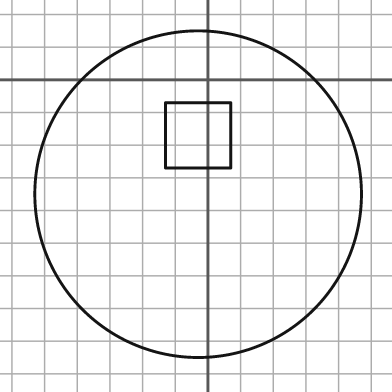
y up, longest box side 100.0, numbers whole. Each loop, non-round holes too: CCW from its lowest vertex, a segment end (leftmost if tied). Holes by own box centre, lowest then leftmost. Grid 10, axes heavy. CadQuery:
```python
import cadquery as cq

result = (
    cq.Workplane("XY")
    .moveTo(-3.0, -35.0)
    .circle(50.0)
    .moveTo(-13.0, -27.0)
    .lineTo(7.0, -27.0)
    .lineTo(7.0, -7.0)
    .lineTo(-13.0, -7.0)
    .close()
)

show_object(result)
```